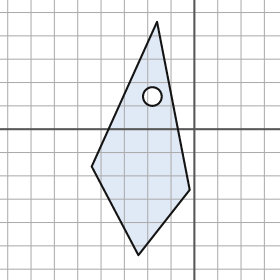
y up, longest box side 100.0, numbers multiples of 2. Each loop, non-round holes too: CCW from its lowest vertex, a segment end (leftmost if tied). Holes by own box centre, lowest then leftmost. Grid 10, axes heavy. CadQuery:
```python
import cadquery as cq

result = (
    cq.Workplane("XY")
    .moveTo(-24.0, -54.0)
    .lineTo(-2.0, -26.0)
    .lineTo(-16.0, 46.0)
    .lineTo(-44.0, -16.0)
    .close()
    .moveTo(-18.0, 14.0)
    .circle(4.0)
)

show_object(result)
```